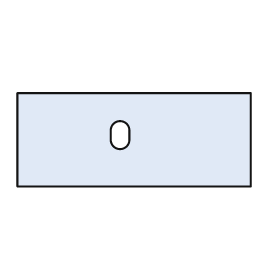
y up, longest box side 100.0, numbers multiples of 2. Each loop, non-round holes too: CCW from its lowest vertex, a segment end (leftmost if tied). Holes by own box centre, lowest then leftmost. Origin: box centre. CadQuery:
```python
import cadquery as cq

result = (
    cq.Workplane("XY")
    .moveTo(-50.0, -20.0)
    .lineTo(50.0, -20.0)
    .lineTo(50.0, 20.0)
    .lineTo(-50.0, 20.0)
    .close()
    .moveTo(-10.0, 0.0)
    .threePointArc((-6.0, -4.0), (-2.0, 0.0))
    .lineTo(-2.0, 4.0)
    .threePointArc((-6.0, 8.0), (-10.0, 4.0))
    .close()
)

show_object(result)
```